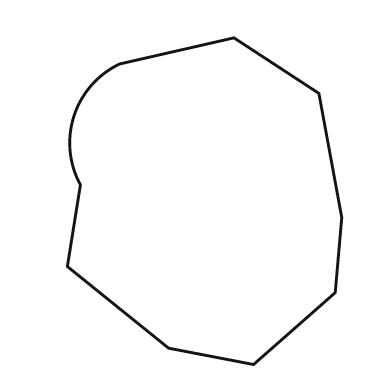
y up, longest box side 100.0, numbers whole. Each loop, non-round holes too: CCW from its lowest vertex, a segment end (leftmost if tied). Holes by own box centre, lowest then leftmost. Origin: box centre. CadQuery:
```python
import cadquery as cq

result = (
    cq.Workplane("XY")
    .moveTo(15.0, -50.0)
    .lineTo(40.0, -28.0)
    .lineTo(42.0, -5.0)
    .lineTo(35.0, 33.0)
    .lineTo(9.0, 50.0)
    .lineTo(-26.0, 42.0)
    .threePointArc((-40.0, 26.0), (-38.0, 5.0))
    .lineTo(-42.0, -20.0)
    .lineTo(-11.0, -45.0)
    .close()
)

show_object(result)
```